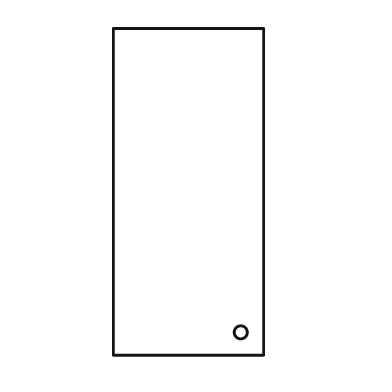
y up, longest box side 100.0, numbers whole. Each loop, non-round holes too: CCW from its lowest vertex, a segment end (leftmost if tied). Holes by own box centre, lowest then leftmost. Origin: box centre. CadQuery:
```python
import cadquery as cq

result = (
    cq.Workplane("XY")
    .moveTo(-23.0, -50.0)
    .lineTo(23.0, -50.0)
    .lineTo(23.0, 50.0)
    .lineTo(-23.0, 50.0)
    .close()
    .moveTo(16.0, -43.0)
    .circle(2.0)
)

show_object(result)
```